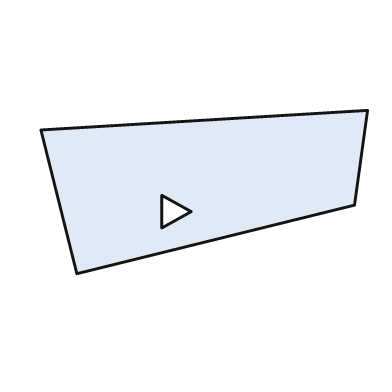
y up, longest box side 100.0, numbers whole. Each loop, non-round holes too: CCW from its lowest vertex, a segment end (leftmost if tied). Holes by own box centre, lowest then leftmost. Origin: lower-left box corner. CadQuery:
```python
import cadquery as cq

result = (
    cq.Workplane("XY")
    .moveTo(11.0, 0.0)
    .lineTo(96.0, 21.0)
    .lineTo(100.0, 50.0)
    .lineTo(0.0, 44.0)
    .close()
    .moveTo(37.0, 14.0)
    .lineTo(46.0, 19.0)
    .lineTo(37.0, 24.0)
    .close()
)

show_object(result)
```